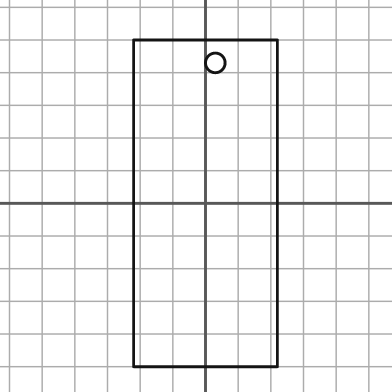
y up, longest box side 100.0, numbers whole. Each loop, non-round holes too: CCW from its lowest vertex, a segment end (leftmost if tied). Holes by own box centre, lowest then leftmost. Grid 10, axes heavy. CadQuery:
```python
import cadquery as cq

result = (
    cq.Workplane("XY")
    .moveTo(-22.0, -50.0)
    .lineTo(22.0, -50.0)
    .lineTo(22.0, 50.0)
    .lineTo(-22.0, 50.0)
    .close()
    .moveTo(3.0, 43.0)
    .circle(3.0)
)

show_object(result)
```